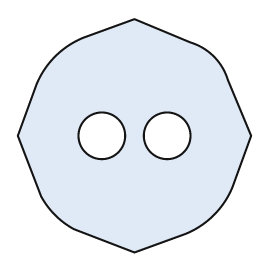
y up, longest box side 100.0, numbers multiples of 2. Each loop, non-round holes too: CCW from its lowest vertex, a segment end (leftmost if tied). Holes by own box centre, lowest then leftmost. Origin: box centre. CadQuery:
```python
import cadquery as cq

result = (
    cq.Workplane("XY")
    .moveTo(0.0, -50.0)
    .lineTo(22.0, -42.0)
    .threePointArc((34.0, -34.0), (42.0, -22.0))
    .lineTo(50.0, 0.0)
    .lineTo(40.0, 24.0)
    .threePointArc((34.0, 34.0), (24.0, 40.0))
    .lineTo(0.0, 50.0)
    .lineTo(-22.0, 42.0)
    .threePointArc((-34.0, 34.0), (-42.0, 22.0))
    .lineTo(-50.0, 0.0)
    .lineTo(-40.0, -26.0)
    .threePointArc((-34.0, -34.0), (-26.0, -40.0))
    .close()
    .moveTo(-14.0, 0.0)
    .circle(10.0)
    .moveTo(14.0, 0.0)
    .circle(10.0)
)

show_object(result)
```